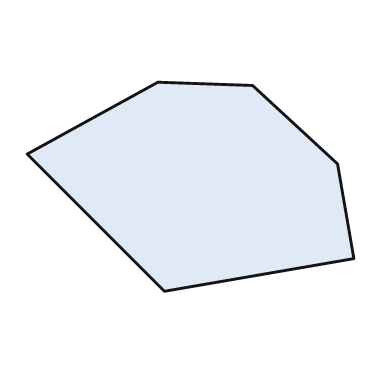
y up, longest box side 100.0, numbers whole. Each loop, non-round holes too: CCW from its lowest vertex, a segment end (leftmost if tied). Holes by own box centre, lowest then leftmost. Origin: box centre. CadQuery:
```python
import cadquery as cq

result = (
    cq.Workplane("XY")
    .moveTo(-8.0, -32.0)
    .lineTo(50.0, -22.0)
    .lineTo(45.0, 7.0)
    .lineTo(19.0, 31.0)
    .lineTo(-10.0, 32.0)
    .lineTo(-50.0, 10.0)
    .close()
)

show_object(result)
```